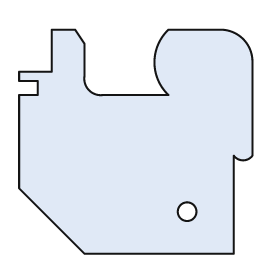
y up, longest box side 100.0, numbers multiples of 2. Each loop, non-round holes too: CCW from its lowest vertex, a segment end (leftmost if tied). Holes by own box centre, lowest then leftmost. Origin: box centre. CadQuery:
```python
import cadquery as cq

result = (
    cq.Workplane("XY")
    .moveTo(-22.0, -48.0)
    .lineTo(42.0, -48.0)
    .lineTo(42.0, -6.0)
    .threePointArc((46.0, -8.0), (50.0, -6.0))
    .lineTo(50.0, 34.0)
    .threePointArc((46.0, 44.0), (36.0, 48.0))
    .lineTo(14.0, 48.0)
    .threePointArc((8.0, 34.0), (14.0, 20.0))
    .lineTo(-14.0, 20.0)
    .threePointArc((-20.0, 22.0), (-22.0, 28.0))
    .lineTo(-22.0, 42.0)
    .lineTo(-26.0, 48.0)
    .lineTo(-36.0, 48.0)
    .lineTo(-36.0, 30.0)
    .lineTo(-50.0, 30.0)
    .lineTo(-50.0, 26.0)
    .lineTo(-42.0, 26.0)
    .lineTo(-42.0, 20.0)
    .lineTo(-50.0, 20.0)
    .lineTo(-50.0, -20.0)
    .close()
    .moveTo(22.0, -30.0)
    .circle(4.0)
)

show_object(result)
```